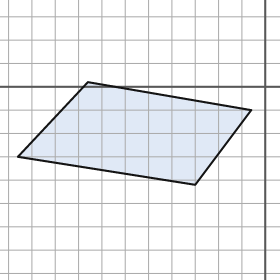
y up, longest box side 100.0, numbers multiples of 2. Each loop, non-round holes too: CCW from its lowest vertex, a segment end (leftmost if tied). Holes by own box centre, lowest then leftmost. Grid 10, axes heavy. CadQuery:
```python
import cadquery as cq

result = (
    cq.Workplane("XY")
    .moveTo(-30.0, -42.0)
    .lineTo(-6.0, -10.0)
    .lineTo(-76.0, 2.0)
    .lineTo(-106.0, -30.0)
    .close()
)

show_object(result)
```